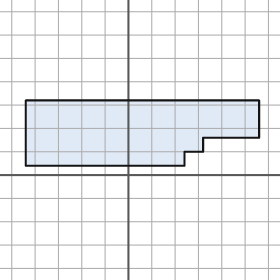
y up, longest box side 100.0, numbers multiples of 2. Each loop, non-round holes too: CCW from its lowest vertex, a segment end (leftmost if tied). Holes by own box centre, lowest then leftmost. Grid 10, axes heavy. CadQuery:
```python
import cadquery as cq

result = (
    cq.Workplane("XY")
    .moveTo(-44.0, 4.0)
    .lineTo(24.0, 4.0)
    .lineTo(24.0, 10.0)
    .lineTo(32.0, 10.0)
    .lineTo(32.0, 16.0)
    .lineTo(56.0, 16.0)
    .lineTo(56.0, 32.0)
    .lineTo(-44.0, 32.0)
    .close()
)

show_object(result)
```